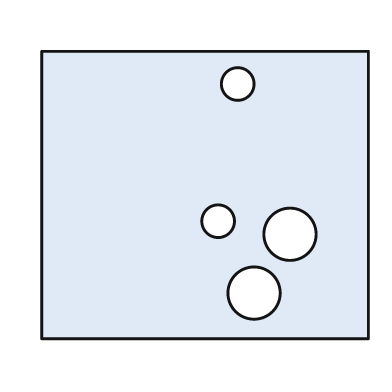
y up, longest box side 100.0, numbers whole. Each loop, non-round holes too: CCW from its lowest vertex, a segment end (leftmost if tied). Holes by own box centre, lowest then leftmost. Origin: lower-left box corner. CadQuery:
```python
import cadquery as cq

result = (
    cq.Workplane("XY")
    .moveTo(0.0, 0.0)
    .lineTo(100.0, 0.0)
    .lineTo(100.0, 88.0)
    .lineTo(0.0, 88.0)
    .close()
    .moveTo(65.0, 14.0)
    .circle(8.0)
    .moveTo(76.0, 32.0)
    .circle(8.0)
    .moveTo(54.0, 36.0)
    .circle(5.0)
    .moveTo(60.0, 78.0)
    .circle(5.0)
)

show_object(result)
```